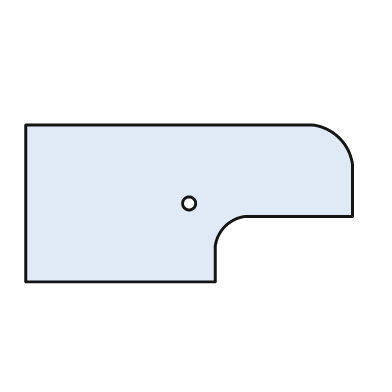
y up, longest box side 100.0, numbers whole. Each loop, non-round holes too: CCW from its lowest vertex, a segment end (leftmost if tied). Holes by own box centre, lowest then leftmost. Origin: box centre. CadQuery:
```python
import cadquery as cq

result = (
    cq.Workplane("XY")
    .moveTo(-50.0, -24.0)
    .lineTo(8.0, -24.0)
    .lineTo(8.0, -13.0)
    .threePointArc((11.0, -7.0), (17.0, -4.0))
    .lineTo(50.0, -4.0)
    .lineTo(50.0, 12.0)
    .threePointArc((46.0, 20.0), (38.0, 24.0))
    .lineTo(-50.0, 24.0)
    .close()
    .moveTo(0.0, 0.0)
    .circle(2.0)
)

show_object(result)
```